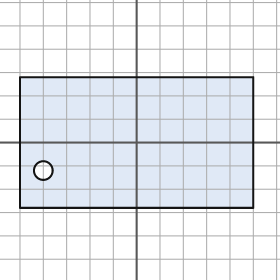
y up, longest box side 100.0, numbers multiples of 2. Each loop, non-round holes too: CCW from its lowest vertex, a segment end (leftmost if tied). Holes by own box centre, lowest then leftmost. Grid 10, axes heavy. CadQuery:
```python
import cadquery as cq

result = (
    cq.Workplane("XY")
    .moveTo(-50.0, -28.0)
    .lineTo(50.0, -28.0)
    .lineTo(50.0, 28.0)
    .lineTo(-50.0, 28.0)
    .close()
    .moveTo(-40.0, -12.0)
    .circle(4.0)
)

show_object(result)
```